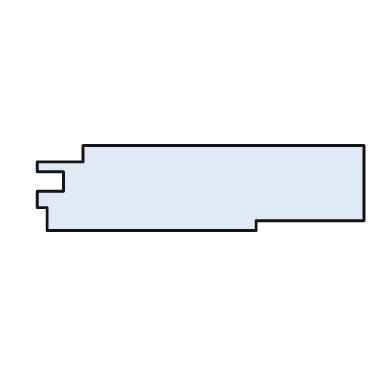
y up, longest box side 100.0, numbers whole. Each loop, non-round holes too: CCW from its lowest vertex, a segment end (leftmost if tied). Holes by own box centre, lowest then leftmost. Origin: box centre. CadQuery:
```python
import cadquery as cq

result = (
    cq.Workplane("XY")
    .moveTo(-47.0, -13.0)
    .lineTo(17.0, -13.0)
    .lineTo(17.0, -10.0)
    .lineTo(50.0, -10.0)
    .lineTo(50.0, 13.0)
    .lineTo(-36.0, 13.0)
    .lineTo(-36.0, 8.0)
    .lineTo(-50.0, 8.0)
    .lineTo(-50.0, 5.0)
    .lineTo(-42.0, 5.0)
    .lineTo(-42.0, -1.0)
    .lineTo(-50.0, -1.0)
    .lineTo(-50.0, -6.0)
    .lineTo(-47.0, -6.0)
    .close()
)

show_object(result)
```